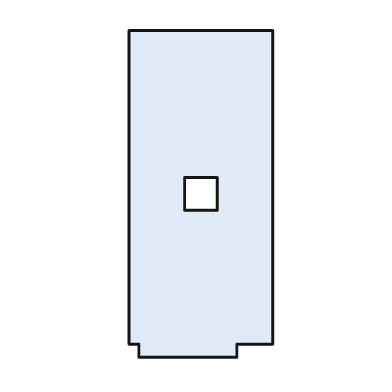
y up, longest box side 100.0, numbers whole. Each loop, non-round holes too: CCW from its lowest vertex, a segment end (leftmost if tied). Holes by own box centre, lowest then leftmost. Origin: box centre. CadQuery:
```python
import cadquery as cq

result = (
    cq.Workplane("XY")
    .moveTo(-19.0, -50.0)
    .lineTo(11.0, -50.0)
    .lineTo(11.0, -46.0)
    .lineTo(22.0, -46.0)
    .lineTo(22.0, 50.0)
    .lineTo(-22.0, 50.0)
    .lineTo(-22.0, -46.0)
    .lineTo(-19.0, -46.0)
    .close()
    .moveTo(-5.0, -5.0)
    .lineTo(5.0, -5.0)
    .lineTo(5.0, 5.0)
    .lineTo(-5.0, 5.0)
    .close()
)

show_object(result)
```